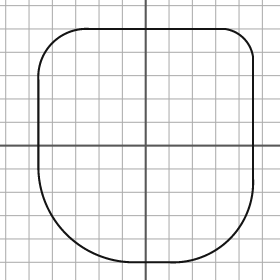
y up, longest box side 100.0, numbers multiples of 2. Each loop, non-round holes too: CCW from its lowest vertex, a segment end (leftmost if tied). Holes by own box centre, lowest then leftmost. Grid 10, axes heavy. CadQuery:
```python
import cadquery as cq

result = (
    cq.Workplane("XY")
    .moveTo(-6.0, -50.0)
    .lineTo(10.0, -50.0)
    .threePointArc((36.0, -40.0), (46.0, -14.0))
    .lineTo(46.0, 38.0)
    .threePointArc((42.0, 46.0), (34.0, 50.0))
    .lineTo(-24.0, 50.0)
    .threePointArc((-40.0, 44.0), (-46.0, 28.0))
    .lineTo(-46.0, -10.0)
    .threePointArc((-34.0, -38.0), (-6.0, -50.0))
    .close()
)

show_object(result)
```